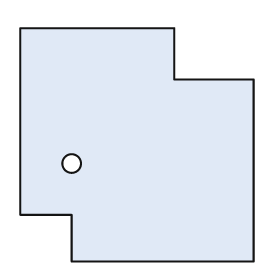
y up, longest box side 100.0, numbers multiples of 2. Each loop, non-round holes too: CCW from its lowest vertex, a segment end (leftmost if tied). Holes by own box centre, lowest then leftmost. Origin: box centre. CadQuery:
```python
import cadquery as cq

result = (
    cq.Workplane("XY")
    .moveTo(-28.0, -50.0)
    .lineTo(50.0, -50.0)
    .lineTo(50.0, 28.0)
    .lineTo(16.0, 28.0)
    .lineTo(16.0, 50.0)
    .lineTo(-50.0, 50.0)
    .lineTo(-50.0, -30.0)
    .lineTo(-28.0, -30.0)
    .close()
    .moveTo(-28.0, -8.0)
    .circle(4.0)
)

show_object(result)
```